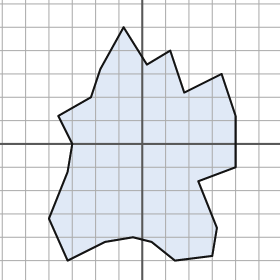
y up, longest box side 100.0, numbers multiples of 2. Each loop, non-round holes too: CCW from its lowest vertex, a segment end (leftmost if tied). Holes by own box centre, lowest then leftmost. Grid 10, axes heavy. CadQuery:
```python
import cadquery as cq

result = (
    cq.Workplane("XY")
    .moveTo(-32.0, -50.0)
    .lineTo(-16.0, -42.0)
    .lineTo(-4.0, -40.0)
    .lineTo(4.0, -42.0)
    .lineTo(14.0, -50.0)
    .lineTo(30.0, -48.0)
    .lineTo(32.0, -36.0)
    .lineTo(24.0, -16.0)
    .lineTo(40.0, -10.0)
    .lineTo(40.0, 12.0)
    .lineTo(34.0, 30.0)
    .lineTo(18.0, 22.0)
    .lineTo(12.0, 40.0)
    .lineTo(2.0, 34.0)
    .lineTo(-8.0, 50.0)
    .lineTo(-18.0, 32.0)
    .lineTo(-22.0, 20.0)
    .lineTo(-36.0, 12.0)
    .lineTo(-30.0, 0.0)
    .lineTo(-32.0, -12.0)
    .lineTo(-40.0, -32.0)
    .close()
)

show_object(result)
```